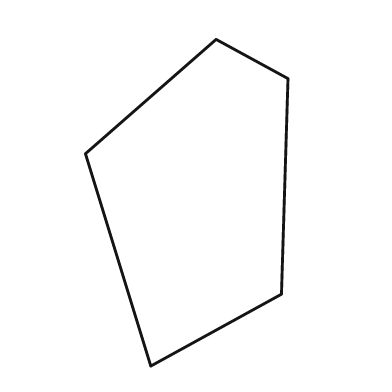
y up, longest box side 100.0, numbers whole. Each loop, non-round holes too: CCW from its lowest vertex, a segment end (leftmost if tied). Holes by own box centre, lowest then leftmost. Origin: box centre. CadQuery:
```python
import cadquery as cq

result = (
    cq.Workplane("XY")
    .moveTo(-11.0, -50.0)
    .lineTo(29.0, -28.0)
    .lineTo(31.0, 38.0)
    .lineTo(9.0, 50.0)
    .lineTo(-31.0, 15.0)
    .close()
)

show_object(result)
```